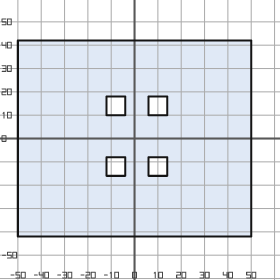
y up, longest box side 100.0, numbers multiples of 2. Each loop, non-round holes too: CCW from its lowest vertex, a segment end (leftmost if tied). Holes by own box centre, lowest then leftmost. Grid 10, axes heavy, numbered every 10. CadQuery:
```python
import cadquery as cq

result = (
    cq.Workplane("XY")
    .moveTo(-50.0, -42.0)
    .lineTo(50.0, -42.0)
    .lineTo(50.0, 42.0)
    .lineTo(-50.0, 42.0)
    .close()
    .moveTo(-12.0, -16.0)
    .lineTo(-4.0, -16.0)
    .lineTo(-4.0, -8.0)
    .lineTo(-12.0, -8.0)
    .close()
    .moveTo(6.0, -16.0)
    .lineTo(14.0, -16.0)
    .lineTo(14.0, -8.0)
    .lineTo(6.0, -8.0)
    .close()
    .moveTo(-12.0, 10.0)
    .lineTo(-4.0, 10.0)
    .lineTo(-4.0, 18.0)
    .lineTo(-12.0, 18.0)
    .close()
    .moveTo(6.0, 10.0)
    .lineTo(14.0, 10.0)
    .lineTo(14.0, 18.0)
    .lineTo(6.0, 18.0)
    .close()
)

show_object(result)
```